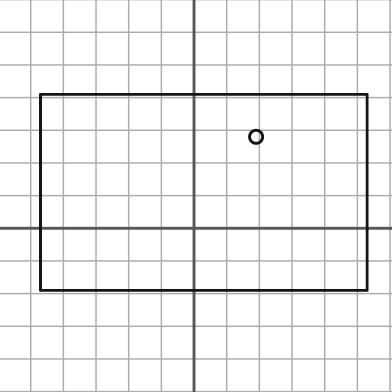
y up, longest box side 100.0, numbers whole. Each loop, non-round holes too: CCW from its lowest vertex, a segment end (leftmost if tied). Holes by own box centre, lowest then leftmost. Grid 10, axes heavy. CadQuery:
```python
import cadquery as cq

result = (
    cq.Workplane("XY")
    .moveTo(-47.0, -19.0)
    .lineTo(53.0, -19.0)
    .lineTo(53.0, 41.0)
    .lineTo(-47.0, 41.0)
    .close()
    .moveTo(19.0, 28.0)
    .circle(2.0)
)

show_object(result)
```